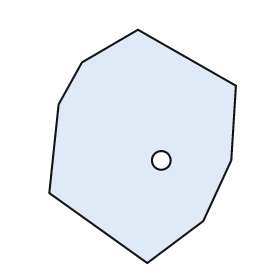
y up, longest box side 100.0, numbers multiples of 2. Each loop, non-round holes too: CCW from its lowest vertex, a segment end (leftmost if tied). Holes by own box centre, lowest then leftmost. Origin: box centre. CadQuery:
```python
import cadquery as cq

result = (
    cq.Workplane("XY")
    .moveTo(2.0, -50.0)
    .lineTo(26.0, -32.0)
    .lineTo(38.0, -6.0)
    .lineTo(40.0, 26.0)
    .lineTo(-2.0, 50.0)
    .lineTo(-26.0, 36.0)
    .lineTo(-36.0, 18.0)
    .lineTo(-40.0, -20.0)
    .close()
    .moveTo(8.0, -6.0)
    .circle(4.0)
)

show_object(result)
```